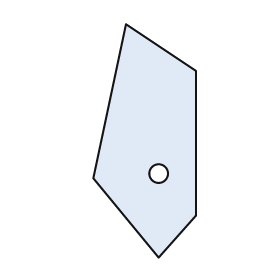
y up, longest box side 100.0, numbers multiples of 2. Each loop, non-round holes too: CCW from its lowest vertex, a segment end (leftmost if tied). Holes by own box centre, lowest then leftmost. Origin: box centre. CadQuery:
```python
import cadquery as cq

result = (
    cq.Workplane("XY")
    .moveTo(6.0, -50.0)
    .lineTo(22.0, -32.0)
    .lineTo(22.0, 30.0)
    .lineTo(-8.0, 50.0)
    .lineTo(-22.0, -16.0)
    .close()
    .moveTo(6.0, -14.0)
    .circle(4.0)
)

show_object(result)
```